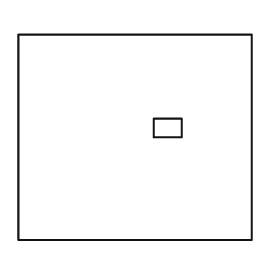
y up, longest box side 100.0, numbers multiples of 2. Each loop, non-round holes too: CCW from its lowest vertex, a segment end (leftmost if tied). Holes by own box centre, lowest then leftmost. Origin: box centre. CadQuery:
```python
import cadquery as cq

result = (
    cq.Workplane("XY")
    .moveTo(-50.0, -44.0)
    .lineTo(50.0, -44.0)
    .lineTo(50.0, 44.0)
    .lineTo(-50.0, 44.0)
    .close()
    .moveTo(8.0, 0.0)
    .lineTo(20.0, 0.0)
    .lineTo(20.0, 8.0)
    .lineTo(8.0, 8.0)
    .close()
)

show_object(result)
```